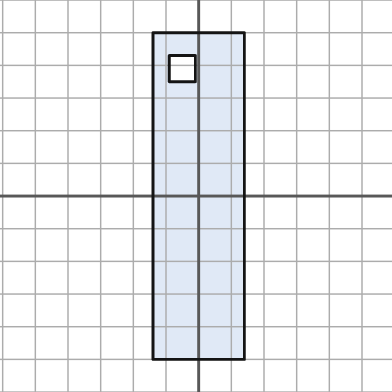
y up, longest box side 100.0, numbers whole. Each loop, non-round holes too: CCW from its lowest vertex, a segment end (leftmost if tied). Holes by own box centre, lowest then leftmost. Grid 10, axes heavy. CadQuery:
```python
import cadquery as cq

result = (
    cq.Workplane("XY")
    .moveTo(-14.0, -50.0)
    .lineTo(14.0, -50.0)
    .lineTo(14.0, 50.0)
    .lineTo(-14.0, 50.0)
    .close()
    .moveTo(-9.0, 35.0)
    .lineTo(-1.0, 35.0)
    .lineTo(-1.0, 43.0)
    .lineTo(-9.0, 43.0)
    .close()
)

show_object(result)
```